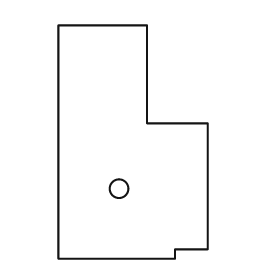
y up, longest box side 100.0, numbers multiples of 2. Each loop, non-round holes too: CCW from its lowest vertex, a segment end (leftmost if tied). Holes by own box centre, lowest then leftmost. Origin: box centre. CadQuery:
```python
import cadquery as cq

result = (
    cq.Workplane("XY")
    .moveTo(-32.0, -50.0)
    .lineTo(18.0, -50.0)
    .lineTo(18.0, -46.0)
    .lineTo(32.0, -46.0)
    .lineTo(32.0, 8.0)
    .lineTo(6.0, 8.0)
    .lineTo(6.0, 50.0)
    .lineTo(-32.0, 50.0)
    .close()
    .moveTo(-6.0, -20.0)
    .circle(4.0)
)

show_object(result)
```